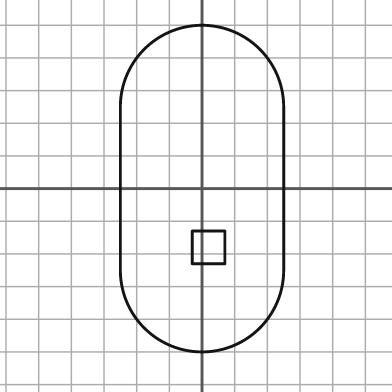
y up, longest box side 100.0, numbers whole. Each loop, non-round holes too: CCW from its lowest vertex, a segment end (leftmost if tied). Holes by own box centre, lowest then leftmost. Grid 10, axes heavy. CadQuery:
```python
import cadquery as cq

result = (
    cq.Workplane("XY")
    .moveTo(-25.0, -25.0)
    .threePointArc((0.0, -50.0), (25.0, -25.0))
    .lineTo(25.0, 25.0)
    .threePointArc((0.0, 50.0), (-25.0, 25.0))
    .close()
    .moveTo(-3.0, -23.0)
    .lineTo(7.0, -23.0)
    .lineTo(7.0, -13.0)
    .lineTo(-3.0, -13.0)
    .close()
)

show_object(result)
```